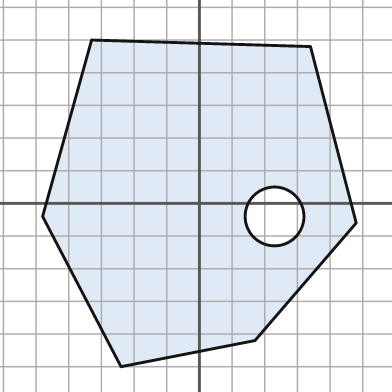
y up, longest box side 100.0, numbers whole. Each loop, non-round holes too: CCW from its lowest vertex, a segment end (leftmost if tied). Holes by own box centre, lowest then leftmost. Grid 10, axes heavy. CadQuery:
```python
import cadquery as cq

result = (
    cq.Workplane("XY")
    .moveTo(-24.0, -50.0)
    .lineTo(17.0, -42.0)
    .lineTo(48.0, -6.0)
    .lineTo(34.0, 48.0)
    .lineTo(-33.0, 50.0)
    .lineTo(-48.0, -4.0)
    .close()
    .moveTo(23.0, -4.0)
    .circle(9.0)
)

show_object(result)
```